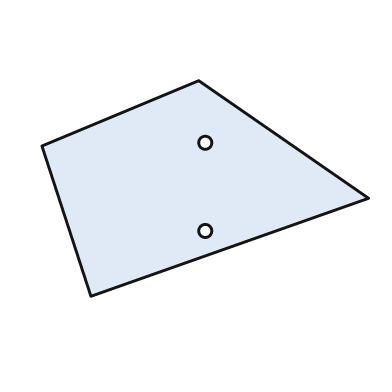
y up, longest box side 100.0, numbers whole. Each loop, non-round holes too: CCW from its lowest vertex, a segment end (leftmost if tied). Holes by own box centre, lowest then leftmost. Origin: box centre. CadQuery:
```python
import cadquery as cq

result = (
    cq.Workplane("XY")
    .moveTo(-35.0, -33.0)
    .lineTo(50.0, -3.0)
    .lineTo(-2.0, 33.0)
    .lineTo(-50.0, 13.0)
    .close()
    .moveTo(0.0, -13.0)
    .circle(2.0)
    .moveTo(0.0, 14.0)
    .circle(2.0)
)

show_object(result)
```